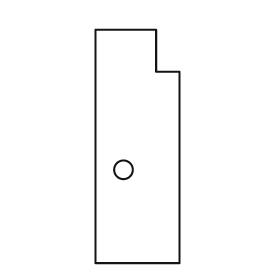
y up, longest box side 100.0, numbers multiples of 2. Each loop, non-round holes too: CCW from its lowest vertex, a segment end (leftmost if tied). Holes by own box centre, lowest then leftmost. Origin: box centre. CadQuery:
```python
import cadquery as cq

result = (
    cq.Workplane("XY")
    .moveTo(-18.0, -50.0)
    .lineTo(18.0, -50.0)
    .lineTo(18.0, 32.0)
    .lineTo(8.0, 32.0)
    .lineTo(8.0, 50.0)
    .lineTo(-18.0, 50.0)
    .close()
    .moveTo(-6.0, -10.0)
    .circle(4.0)
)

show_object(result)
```